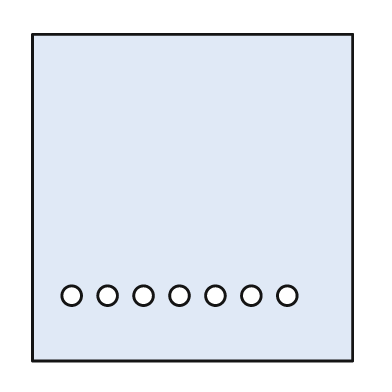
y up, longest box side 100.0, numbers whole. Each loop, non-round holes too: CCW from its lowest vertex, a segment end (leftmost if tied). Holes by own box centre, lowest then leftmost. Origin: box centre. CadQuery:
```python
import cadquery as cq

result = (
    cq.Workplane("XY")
    .moveTo(-49.0, -50.0)
    .lineTo(49.0, -50.0)
    .lineTo(49.0, 50.0)
    .lineTo(-49.0, 50.0)
    .close()
    .moveTo(-37.0, -30.0)
    .circle(3.0)
    .moveTo(-26.0, -30.0)
    .circle(3.0)
    .moveTo(-15.0, -30.0)
    .circle(3.0)
    .moveTo(-4.0, -30.0)
    .circle(3.0)
    .moveTo(7.0, -30.0)
    .circle(3.0)
    .moveTo(18.0, -30.0)
    .circle(3.0)
    .moveTo(29.0, -30.0)
    .circle(3.0)
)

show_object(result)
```